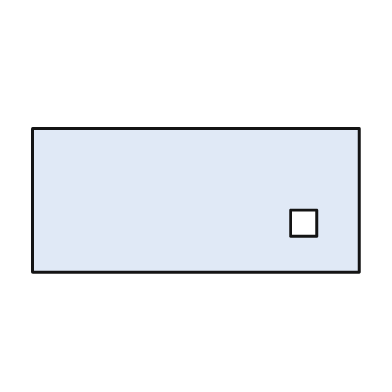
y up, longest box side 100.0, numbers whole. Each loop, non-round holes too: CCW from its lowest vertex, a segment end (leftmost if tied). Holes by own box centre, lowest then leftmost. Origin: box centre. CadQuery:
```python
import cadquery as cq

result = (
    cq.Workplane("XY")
    .moveTo(-50.0, -22.0)
    .lineTo(50.0, -22.0)
    .lineTo(50.0, 22.0)
    .lineTo(-50.0, 22.0)
    .close()
    .moveTo(29.0, -11.0)
    .lineTo(37.0, -11.0)
    .lineTo(37.0, -3.0)
    .lineTo(29.0, -3.0)
    .close()
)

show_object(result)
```